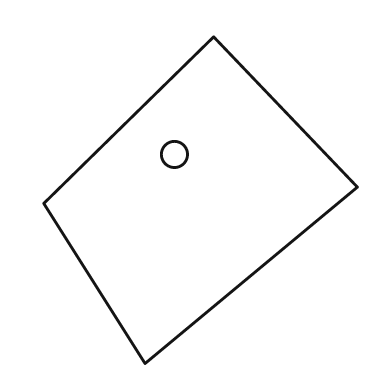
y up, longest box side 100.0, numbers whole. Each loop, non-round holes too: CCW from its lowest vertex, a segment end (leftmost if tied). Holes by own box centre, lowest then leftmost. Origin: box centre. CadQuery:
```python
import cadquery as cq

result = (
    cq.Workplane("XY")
    .moveTo(-17.0, -50.0)
    .lineTo(48.0, 4.0)
    .lineTo(4.0, 50.0)
    .lineTo(-48.0, -1.0)
    .close()
    .moveTo(-8.0, 14.0)
    .circle(4.0)
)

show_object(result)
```